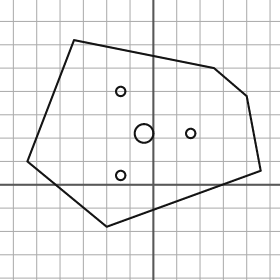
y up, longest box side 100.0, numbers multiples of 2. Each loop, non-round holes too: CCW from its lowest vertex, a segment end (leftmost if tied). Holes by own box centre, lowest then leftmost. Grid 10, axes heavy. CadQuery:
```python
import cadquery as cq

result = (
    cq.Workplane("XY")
    .moveTo(-20.0, -18.0)
    .lineTo(46.0, 6.0)
    .lineTo(40.0, 38.0)
    .lineTo(26.0, 50.0)
    .lineTo(-34.0, 62.0)
    .lineTo(-54.0, 10.0)
    .close()
    .moveTo(-14.0, 4.0)
    .circle(2.0)
    .moveTo(-4.0, 22.0)
    .circle(4.0)
    .moveTo(16.0, 22.0)
    .circle(2.0)
    .moveTo(-14.0, 40.0)
    .circle(2.0)
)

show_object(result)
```